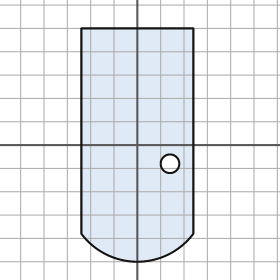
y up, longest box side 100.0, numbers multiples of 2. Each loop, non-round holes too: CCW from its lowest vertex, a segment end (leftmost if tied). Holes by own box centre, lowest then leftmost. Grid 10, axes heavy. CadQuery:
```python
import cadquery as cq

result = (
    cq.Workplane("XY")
    .moveTo(-24.0, -38.0)
    .threePointArc((0.0, -50.0), (24.0, -38.0))
    .lineTo(24.0, 50.0)
    .lineTo(-24.0, 50.0)
    .close()
    .moveTo(14.0, -8.0)
    .circle(4.0)
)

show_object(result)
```